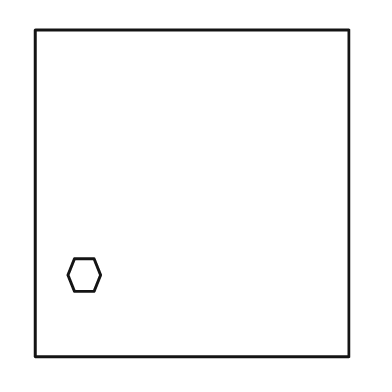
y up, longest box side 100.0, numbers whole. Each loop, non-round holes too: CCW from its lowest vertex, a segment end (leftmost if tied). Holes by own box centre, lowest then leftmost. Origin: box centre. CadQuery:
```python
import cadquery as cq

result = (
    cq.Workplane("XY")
    .moveTo(-48.0, -50.0)
    .lineTo(48.0, -50.0)
    .lineTo(48.0, 50.0)
    .lineTo(-48.0, 50.0)
    .close()
    .moveTo(-36.0, -30.0)
    .lineTo(-30.0, -30.0)
    .lineTo(-28.0, -25.0)
    .lineTo(-30.0, -20.0)
    .lineTo(-36.0, -20.0)
    .lineTo(-38.0, -25.0)
    .close()
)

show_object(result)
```